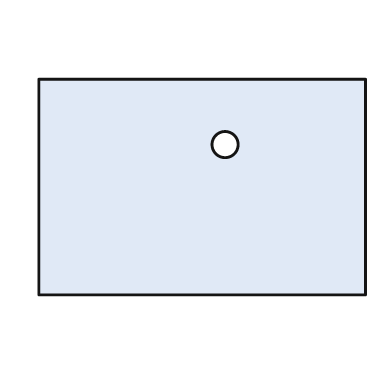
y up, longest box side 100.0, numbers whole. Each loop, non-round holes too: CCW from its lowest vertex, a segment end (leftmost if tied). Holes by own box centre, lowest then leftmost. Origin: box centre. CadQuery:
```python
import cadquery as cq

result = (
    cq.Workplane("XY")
    .moveTo(-50.0, -33.0)
    .lineTo(50.0, -33.0)
    .lineTo(50.0, 33.0)
    .lineTo(-50.0, 33.0)
    .close()
    .moveTo(7.0, 13.0)
    .circle(4.0)
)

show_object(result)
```